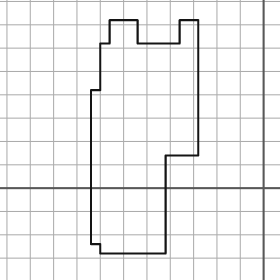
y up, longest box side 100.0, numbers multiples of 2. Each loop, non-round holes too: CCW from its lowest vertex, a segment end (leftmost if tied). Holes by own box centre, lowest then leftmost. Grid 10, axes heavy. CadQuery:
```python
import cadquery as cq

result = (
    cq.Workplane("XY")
    .moveTo(-70.0, -28.0)
    .lineTo(-42.0, -28.0)
    .lineTo(-42.0, 14.0)
    .lineTo(-28.0, 14.0)
    .lineTo(-28.0, 72.0)
    .lineTo(-36.0, 72.0)
    .lineTo(-36.0, 62.0)
    .lineTo(-54.0, 62.0)
    .lineTo(-54.0, 72.0)
    .lineTo(-66.0, 72.0)
    .lineTo(-66.0, 62.0)
    .lineTo(-70.0, 62.0)
    .lineTo(-70.0, 42.0)
    .lineTo(-74.0, 42.0)
    .lineTo(-74.0, -24.0)
    .lineTo(-70.0, -24.0)
    .close()
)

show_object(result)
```